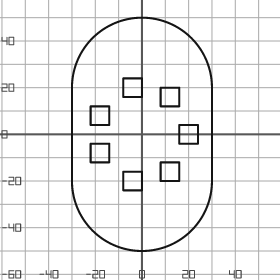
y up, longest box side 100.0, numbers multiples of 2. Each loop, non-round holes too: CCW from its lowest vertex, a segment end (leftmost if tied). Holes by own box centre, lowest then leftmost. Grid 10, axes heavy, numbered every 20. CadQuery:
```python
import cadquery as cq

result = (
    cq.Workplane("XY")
    .moveTo(-30.0, -20.0)
    .threePointArc((0.0, -50.0), (30.0, -20.0))
    .lineTo(30.0, 20.0)
    .threePointArc((0.0, 50.0), (-30.0, 20.0))
    .close()
    .moveTo(-8.0, -24.0)
    .lineTo(0.0, -24.0)
    .lineTo(0.0, -16.0)
    .lineTo(-8.0, -16.0)
    .close()
    .moveTo(8.0, -20.0)
    .lineTo(16.0, -20.0)
    .lineTo(16.0, -12.0)
    .lineTo(8.0, -12.0)
    .close()
    .moveTo(-22.0, -12.0)
    .lineTo(-14.0, -12.0)
    .lineTo(-14.0, -4.0)
    .lineTo(-22.0, -4.0)
    .close()
    .moveTo(16.0, -4.0)
    .lineTo(24.0, -4.0)
    .lineTo(24.0, 4.0)
    .lineTo(16.0, 4.0)
    .close()
    .moveTo(-22.0, 4.0)
    .lineTo(-14.0, 4.0)
    .lineTo(-14.0, 12.0)
    .lineTo(-22.0, 12.0)
    .close()
    .moveTo(8.0, 12.0)
    .lineTo(16.0, 12.0)
    .lineTo(16.0, 20.0)
    .lineTo(8.0, 20.0)
    .close()
    .moveTo(-8.0, 16.0)
    .lineTo(0.0, 16.0)
    .lineTo(0.0, 24.0)
    .lineTo(-8.0, 24.0)
    .close()
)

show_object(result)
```